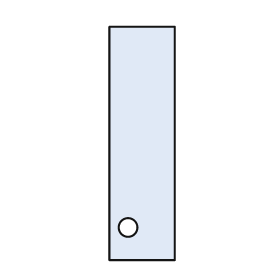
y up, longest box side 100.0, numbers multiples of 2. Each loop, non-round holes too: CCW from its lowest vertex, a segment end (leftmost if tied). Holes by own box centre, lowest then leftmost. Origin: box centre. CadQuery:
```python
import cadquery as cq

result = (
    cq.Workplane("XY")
    .moveTo(-14.0, -50.0)
    .lineTo(14.0, -50.0)
    .lineTo(14.0, 50.0)
    .lineTo(-14.0, 50.0)
    .close()
    .moveTo(-6.0, -36.0)
    .circle(4.0)
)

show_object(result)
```